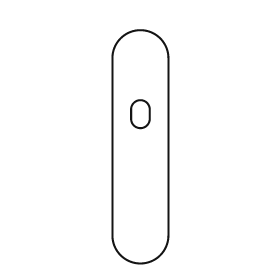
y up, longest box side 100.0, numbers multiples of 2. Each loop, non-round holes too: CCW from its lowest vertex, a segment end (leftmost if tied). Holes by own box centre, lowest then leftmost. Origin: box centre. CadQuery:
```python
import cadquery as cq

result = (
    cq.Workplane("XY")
    .moveTo(-12.0, -38.0)
    .threePointArc((0.0, -50.0), (12.0, -38.0))
    .lineTo(12.0, 38.0)
    .threePointArc((0.0, 50.0), (-12.0, 38.0))
    .close()
    .moveTo(-4.0, 12.0)
    .threePointArc((0.0, 8.0), (4.0, 12.0))
    .lineTo(4.0, 16.0)
    .threePointArc((0.0, 20.0), (-4.0, 16.0))
    .close()
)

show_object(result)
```